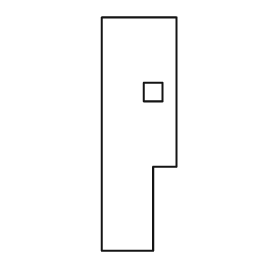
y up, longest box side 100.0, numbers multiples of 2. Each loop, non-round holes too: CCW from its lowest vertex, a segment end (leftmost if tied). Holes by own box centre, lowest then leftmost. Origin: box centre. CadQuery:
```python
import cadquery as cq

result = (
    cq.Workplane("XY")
    .moveTo(-16.0, -50.0)
    .lineTo(6.0, -50.0)
    .lineTo(6.0, -14.0)
    .lineTo(16.0, -14.0)
    .lineTo(16.0, 50.0)
    .lineTo(-16.0, 50.0)
    .close()
    .moveTo(2.0, 14.0)
    .lineTo(10.0, 14.0)
    .lineTo(10.0, 22.0)
    .lineTo(2.0, 22.0)
    .close()
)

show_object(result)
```